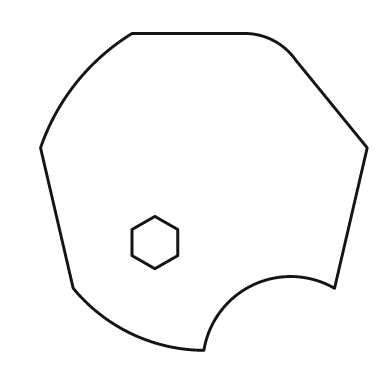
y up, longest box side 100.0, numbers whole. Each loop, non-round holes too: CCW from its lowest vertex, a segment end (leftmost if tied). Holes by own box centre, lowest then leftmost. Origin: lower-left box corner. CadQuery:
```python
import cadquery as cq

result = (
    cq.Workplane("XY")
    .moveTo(50.0, 0.0)
    .threePointArc((65.0, 20.0), (90.0, 19.0))
    .lineTo(100.0, 62.0)
    .lineTo(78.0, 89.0)
    .threePointArc((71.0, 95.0), (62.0, 97.0))
    .lineTo(28.0, 97.0)
    .threePointArc((11.0, 82.0), (0.0, 62.0))
    .lineTo(10.0, 19.0)
    .threePointArc((28.0, 5.0), (50.0, 0.0))
    .close()
    .moveTo(35.0, 25.0)
    .lineTo(42.0, 29.0)
    .lineTo(42.0, 37.0)
    .lineTo(35.0, 41.0)
    .lineTo(28.0, 37.0)
    .lineTo(28.0, 29.0)
    .close()
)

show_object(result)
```